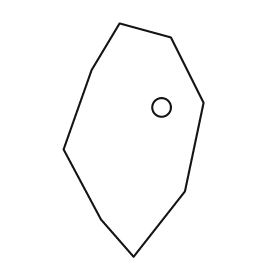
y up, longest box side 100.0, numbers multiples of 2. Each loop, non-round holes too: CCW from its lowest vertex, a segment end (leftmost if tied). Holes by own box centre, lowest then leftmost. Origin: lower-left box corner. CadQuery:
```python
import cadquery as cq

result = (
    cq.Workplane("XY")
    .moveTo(30.0, 0.0)
    .lineTo(52.0, 28.0)
    .lineTo(60.0, 66.0)
    .lineTo(46.0, 94.0)
    .lineTo(24.0, 100.0)
    .lineTo(12.0, 80.0)
    .lineTo(0.0, 46.0)
    .lineTo(16.0, 16.0)
    .close()
    .moveTo(42.0, 64.0)
    .circle(4.0)
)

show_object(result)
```